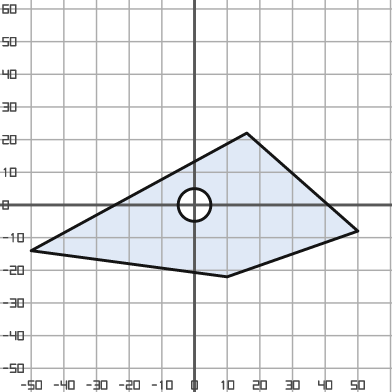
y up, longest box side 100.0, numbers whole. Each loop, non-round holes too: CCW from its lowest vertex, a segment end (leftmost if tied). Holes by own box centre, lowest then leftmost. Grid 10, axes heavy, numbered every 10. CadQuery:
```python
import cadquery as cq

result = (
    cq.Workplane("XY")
    .moveTo(10.0, -22.0)
    .lineTo(50.0, -8.0)
    .lineTo(16.0, 22.0)
    .lineTo(-50.0, -14.0)
    .close()
    .moveTo(0.0, 0.0)
    .circle(5.0)
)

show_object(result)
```